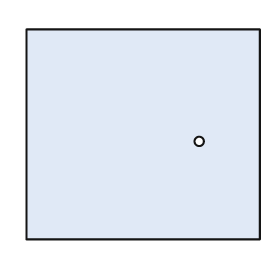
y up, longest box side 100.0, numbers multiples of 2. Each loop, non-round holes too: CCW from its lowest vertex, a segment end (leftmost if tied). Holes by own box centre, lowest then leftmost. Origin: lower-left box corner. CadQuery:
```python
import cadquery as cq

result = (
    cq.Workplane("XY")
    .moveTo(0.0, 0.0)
    .lineTo(100.0, 0.0)
    .lineTo(100.0, 90.0)
    .lineTo(0.0, 90.0)
    .close()
    .moveTo(74.0, 42.0)
    .circle(2.0)
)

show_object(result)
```